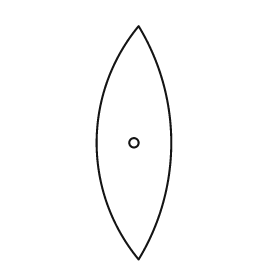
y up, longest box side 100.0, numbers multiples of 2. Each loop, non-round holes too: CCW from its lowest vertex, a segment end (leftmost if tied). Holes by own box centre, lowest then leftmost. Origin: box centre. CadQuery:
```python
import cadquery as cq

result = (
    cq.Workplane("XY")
    .moveTo(2.0, -50.0)
    .threePointArc((16.0, 0.0), (2.0, 50.0))
    .threePointArc((-16.0, 0.0), (2.0, -50.0))
    .close()
    .moveTo(0.0, 0.0)
    .circle(2.0)
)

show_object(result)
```